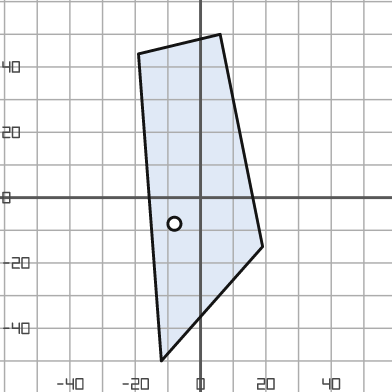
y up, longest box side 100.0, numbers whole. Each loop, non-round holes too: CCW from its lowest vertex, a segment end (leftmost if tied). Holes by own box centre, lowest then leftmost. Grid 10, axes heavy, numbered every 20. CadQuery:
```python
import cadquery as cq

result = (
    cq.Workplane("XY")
    .moveTo(-12.0, -50.0)
    .lineTo(19.0, -15.0)
    .lineTo(6.0, 50.0)
    .lineTo(-19.0, 44.0)
    .close()
    .moveTo(-8.0, -8.0)
    .circle(2.0)
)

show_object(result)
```